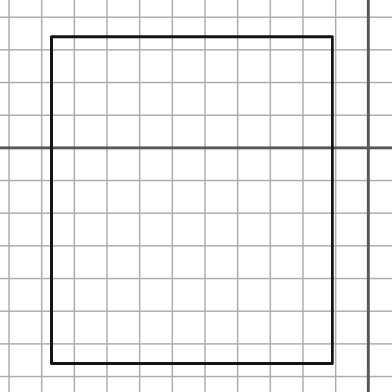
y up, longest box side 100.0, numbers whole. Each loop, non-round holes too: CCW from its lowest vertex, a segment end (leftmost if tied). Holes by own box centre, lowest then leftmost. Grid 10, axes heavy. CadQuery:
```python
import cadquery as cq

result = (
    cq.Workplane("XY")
    .moveTo(-97.0, -66.0)
    .lineTo(-11.0, -66.0)
    .lineTo(-11.0, 34.0)
    .lineTo(-97.0, 34.0)
    .close()
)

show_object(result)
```